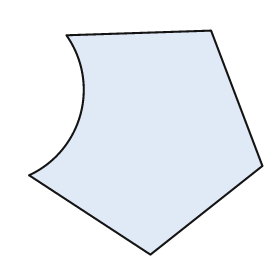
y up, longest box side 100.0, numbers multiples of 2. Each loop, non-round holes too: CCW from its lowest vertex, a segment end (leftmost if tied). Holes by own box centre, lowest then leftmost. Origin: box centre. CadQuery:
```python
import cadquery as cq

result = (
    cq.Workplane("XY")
    .moveTo(2.0, -48.0)
    .lineTo(50.0, -10.0)
    .lineTo(28.0, 48.0)
    .lineTo(-34.0, 46.0)
    .threePointArc((-28.0, 12.0), (-50.0, -14.0))
    .close()
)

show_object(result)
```